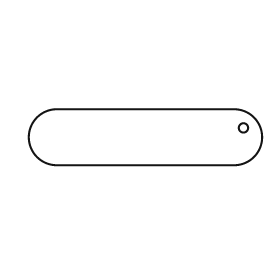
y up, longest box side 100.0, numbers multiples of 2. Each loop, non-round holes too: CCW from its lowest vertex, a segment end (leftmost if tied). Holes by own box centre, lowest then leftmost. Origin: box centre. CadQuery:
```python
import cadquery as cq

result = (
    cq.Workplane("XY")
    .moveTo(-38.0, -12.0)
    .lineTo(38.0, -12.0)
    .threePointArc((50.0, 0.0), (38.0, 12.0))
    .lineTo(-38.0, 12.0)
    .threePointArc((-50.0, 0.0), (-38.0, -12.0))
    .close()
    .moveTo(42.0, 4.0)
    .circle(2.0)
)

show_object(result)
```